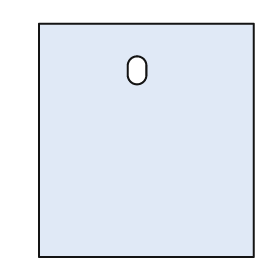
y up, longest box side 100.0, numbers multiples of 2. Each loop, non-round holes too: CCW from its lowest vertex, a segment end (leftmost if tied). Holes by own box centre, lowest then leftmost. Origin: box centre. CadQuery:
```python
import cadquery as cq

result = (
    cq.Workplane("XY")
    .moveTo(-46.0, -50.0)
    .lineTo(46.0, -50.0)
    .lineTo(46.0, 50.0)
    .lineTo(-46.0, 50.0)
    .close()
    .moveTo(-8.0, 28.0)
    .threePointArc((-4.0, 24.0), (0.0, 28.0))
    .lineTo(0.0, 32.0)
    .threePointArc((-4.0, 36.0), (-8.0, 32.0))
    .close()
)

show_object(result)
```